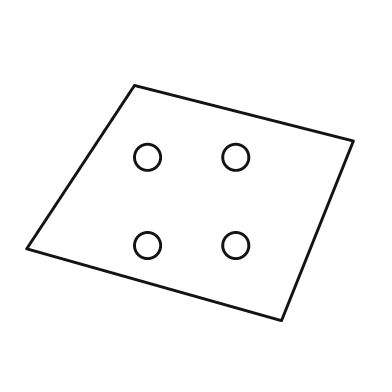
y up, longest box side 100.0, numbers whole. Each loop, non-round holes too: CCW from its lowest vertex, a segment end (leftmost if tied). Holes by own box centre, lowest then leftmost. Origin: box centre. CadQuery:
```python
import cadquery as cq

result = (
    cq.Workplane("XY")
    .moveTo(28.0, -36.0)
    .lineTo(50.0, 19.0)
    .lineTo(-17.0, 36.0)
    .lineTo(-50.0, -14.0)
    .close()
    .moveTo(-13.0, -13.0)
    .circle(4.0)
    .moveTo(14.0, -13.0)
    .circle(4.0)
    .moveTo(-13.0, 14.0)
    .circle(4.0)
    .moveTo(14.0, 14.0)
    .circle(4.0)
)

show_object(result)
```